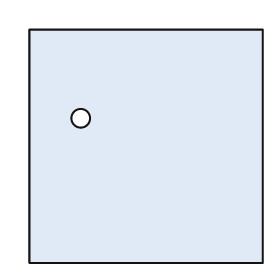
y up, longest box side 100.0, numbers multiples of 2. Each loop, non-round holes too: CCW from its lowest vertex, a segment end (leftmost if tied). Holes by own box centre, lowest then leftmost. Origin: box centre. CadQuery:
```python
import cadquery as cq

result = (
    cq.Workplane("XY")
    .moveTo(-50.0, -50.0)
    .lineTo(50.0, -50.0)
    .lineTo(50.0, 50.0)
    .lineTo(-50.0, 50.0)
    .close()
    .moveTo(-28.0, 12.0)
    .circle(4.0)
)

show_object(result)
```